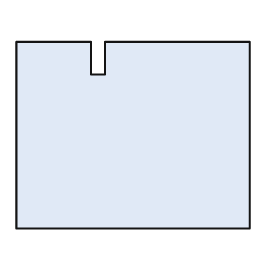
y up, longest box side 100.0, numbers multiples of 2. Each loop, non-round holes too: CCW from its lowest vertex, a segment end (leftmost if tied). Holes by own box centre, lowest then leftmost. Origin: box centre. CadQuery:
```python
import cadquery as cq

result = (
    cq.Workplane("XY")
    .moveTo(-50.0, -40.0)
    .lineTo(50.0, -40.0)
    .lineTo(50.0, 40.0)
    .lineTo(-12.0, 40.0)
    .lineTo(-12.0, 26.0)
    .lineTo(-18.0, 26.0)
    .lineTo(-18.0, 40.0)
    .lineTo(-50.0, 40.0)
    .close()
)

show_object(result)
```